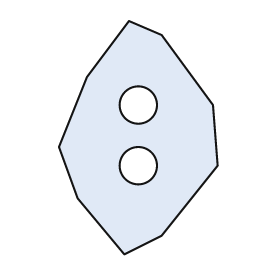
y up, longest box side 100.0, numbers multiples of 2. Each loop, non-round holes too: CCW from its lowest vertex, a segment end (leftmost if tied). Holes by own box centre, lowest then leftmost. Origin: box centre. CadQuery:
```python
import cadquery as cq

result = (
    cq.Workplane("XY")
    .moveTo(-6.0, -50.0)
    .lineTo(10.0, -42.0)
    .lineTo(34.0, -12.0)
    .lineTo(32.0, 14.0)
    .lineTo(10.0, 44.0)
    .lineTo(-4.0, 50.0)
    .lineTo(-22.0, 26.0)
    .lineTo(-34.0, -4.0)
    .lineTo(-26.0, -26.0)
    .close()
    .moveTo(0.0, -12.0)
    .circle(8.0)
    .moveTo(0.0, 14.0)
    .circle(8.0)
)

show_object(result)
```